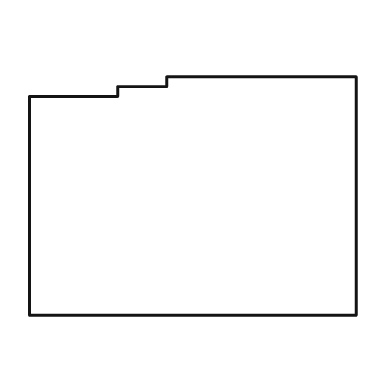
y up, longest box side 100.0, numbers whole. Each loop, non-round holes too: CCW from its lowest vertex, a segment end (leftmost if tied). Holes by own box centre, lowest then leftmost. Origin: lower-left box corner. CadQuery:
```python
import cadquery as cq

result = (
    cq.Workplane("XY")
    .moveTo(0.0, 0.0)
    .lineTo(100.0, 0.0)
    .lineTo(100.0, 73.0)
    .lineTo(42.0, 73.0)
    .lineTo(42.0, 70.0)
    .lineTo(27.0, 70.0)
    .lineTo(27.0, 67.0)
    .lineTo(0.0, 67.0)
    .close()
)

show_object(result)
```